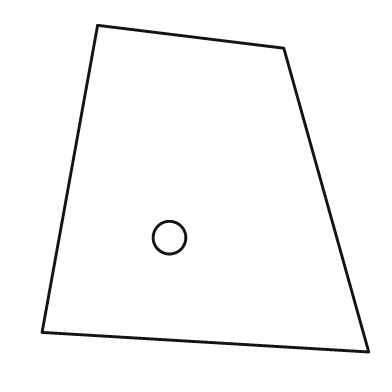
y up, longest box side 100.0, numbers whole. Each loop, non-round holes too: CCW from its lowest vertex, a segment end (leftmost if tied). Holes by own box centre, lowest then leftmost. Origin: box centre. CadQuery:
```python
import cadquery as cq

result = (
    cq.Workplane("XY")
    .moveTo(50.0, -50.0)
    .lineTo(24.0, 43.0)
    .lineTo(-33.0, 50.0)
    .lineTo(-50.0, -44.0)
    .close()
    .moveTo(-11.0, -15.0)
    .circle(5.0)
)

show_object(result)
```